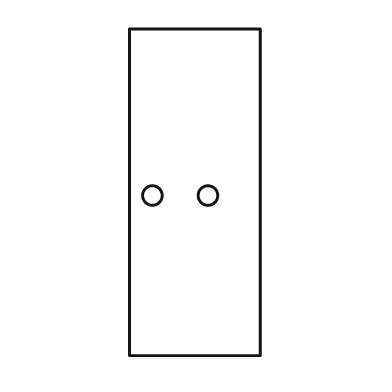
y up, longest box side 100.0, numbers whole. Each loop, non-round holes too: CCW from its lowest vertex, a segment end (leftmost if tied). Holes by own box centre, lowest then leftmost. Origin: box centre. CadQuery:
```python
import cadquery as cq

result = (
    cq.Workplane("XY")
    .moveTo(-20.0, -50.0)
    .lineTo(20.0, -50.0)
    .lineTo(20.0, 50.0)
    .lineTo(-20.0, 50.0)
    .close()
    .moveTo(-13.0, -1.0)
    .circle(3.0)
    .moveTo(4.0, -1.0)
    .circle(3.0)
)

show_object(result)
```